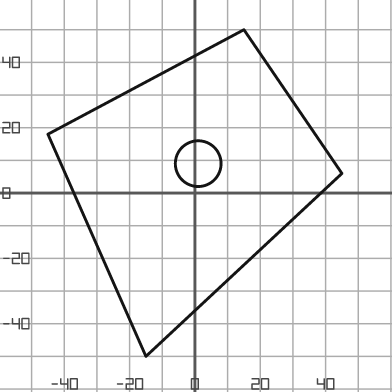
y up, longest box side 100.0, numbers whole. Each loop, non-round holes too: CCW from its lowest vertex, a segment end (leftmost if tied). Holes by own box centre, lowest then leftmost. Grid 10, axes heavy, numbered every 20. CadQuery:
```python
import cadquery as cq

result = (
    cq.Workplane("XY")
    .moveTo(-15.0, -50.0)
    .lineTo(45.0, 6.0)
    .lineTo(15.0, 50.0)
    .lineTo(-45.0, 18.0)
    .close()
    .moveTo(1.0, 9.0)
    .circle(7.0)
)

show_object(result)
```